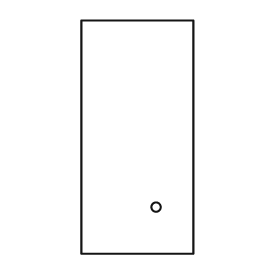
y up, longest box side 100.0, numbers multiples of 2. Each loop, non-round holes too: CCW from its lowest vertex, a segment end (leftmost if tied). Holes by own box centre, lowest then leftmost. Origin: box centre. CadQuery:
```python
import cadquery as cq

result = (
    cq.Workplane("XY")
    .moveTo(-24.0, -50.0)
    .lineTo(24.0, -50.0)
    .lineTo(24.0, 50.0)
    .lineTo(-24.0, 50.0)
    .close()
    .moveTo(8.0, -30.0)
    .circle(2.0)
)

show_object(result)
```